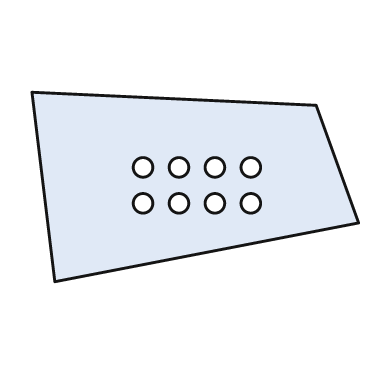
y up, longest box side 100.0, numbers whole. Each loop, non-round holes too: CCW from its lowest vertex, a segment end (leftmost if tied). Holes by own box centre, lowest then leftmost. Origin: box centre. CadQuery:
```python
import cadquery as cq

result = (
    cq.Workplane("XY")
    .moveTo(-43.0, -29.0)
    .lineTo(50.0, -11.0)
    .lineTo(37.0, 25.0)
    .lineTo(-50.0, 29.0)
    .close()
    .moveTo(-16.0, -5.0)
    .circle(3.0)
    .moveTo(-5.0, -5.0)
    .circle(3.0)
    .moveTo(6.0, -5.0)
    .circle(3.0)
    .moveTo(17.0, -5.0)
    .circle(3.0)
    .moveTo(-16.0, 6.0)
    .circle(3.0)
    .moveTo(-5.0, 6.0)
    .circle(3.0)
    .moveTo(6.0, 6.0)
    .circle(3.0)
    .moveTo(17.0, 6.0)
    .circle(3.0)
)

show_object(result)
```